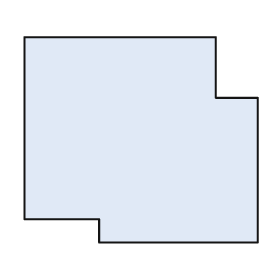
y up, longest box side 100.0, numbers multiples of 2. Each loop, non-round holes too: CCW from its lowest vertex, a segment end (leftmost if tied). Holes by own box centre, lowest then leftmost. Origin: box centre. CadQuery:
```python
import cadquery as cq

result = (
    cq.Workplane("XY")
    .moveTo(-18.0, -44.0)
    .lineTo(50.0, -44.0)
    .lineTo(50.0, 18.0)
    .lineTo(32.0, 18.0)
    .lineTo(32.0, 44.0)
    .lineTo(-50.0, 44.0)
    .lineTo(-50.0, -34.0)
    .lineTo(-18.0, -34.0)
    .close()
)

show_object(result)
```